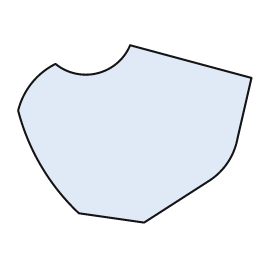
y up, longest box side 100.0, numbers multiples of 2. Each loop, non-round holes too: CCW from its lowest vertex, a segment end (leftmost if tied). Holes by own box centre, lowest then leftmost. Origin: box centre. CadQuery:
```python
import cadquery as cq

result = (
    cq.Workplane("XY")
    .moveTo(4.0, -38.0)
    .lineTo(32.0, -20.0)
    .threePointArc((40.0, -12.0), (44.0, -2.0))
    .lineTo(50.0, 24.0)
    .lineTo(-2.0, 38.0)
    .threePointArc((-16.0, 26.0), (-34.0, 30.0))
    .threePointArc((-44.0, 22.0), (-50.0, 10.0))
    .threePointArc((-40.0, -14.0), (-24.0, -34.0))
    .close()
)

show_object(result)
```